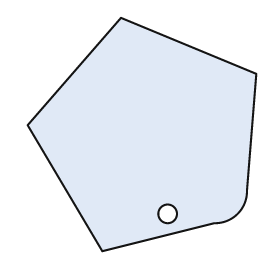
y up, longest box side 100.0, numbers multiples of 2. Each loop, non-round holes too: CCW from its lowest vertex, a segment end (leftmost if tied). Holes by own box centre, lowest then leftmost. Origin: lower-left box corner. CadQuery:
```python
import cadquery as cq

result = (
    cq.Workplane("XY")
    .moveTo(32.0, 0.0)
    .lineTo(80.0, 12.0)
    .threePointArc((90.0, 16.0), (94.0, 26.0))
    .lineTo(98.0, 76.0)
    .lineTo(40.0, 100.0)
    .lineTo(0.0, 54.0)
    .close()
    .moveTo(60.0, 16.0)
    .circle(4.0)
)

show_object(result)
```